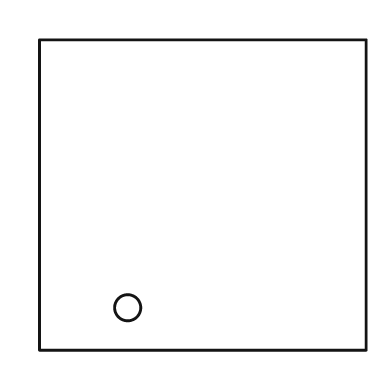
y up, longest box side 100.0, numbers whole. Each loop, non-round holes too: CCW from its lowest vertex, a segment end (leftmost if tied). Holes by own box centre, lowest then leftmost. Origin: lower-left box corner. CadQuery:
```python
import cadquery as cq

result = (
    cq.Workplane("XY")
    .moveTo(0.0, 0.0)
    .lineTo(100.0, 0.0)
    .lineTo(100.0, 95.0)
    .lineTo(0.0, 95.0)
    .close()
    .moveTo(27.0, 13.0)
    .circle(4.0)
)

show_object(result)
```